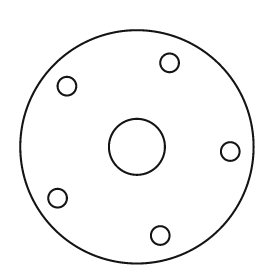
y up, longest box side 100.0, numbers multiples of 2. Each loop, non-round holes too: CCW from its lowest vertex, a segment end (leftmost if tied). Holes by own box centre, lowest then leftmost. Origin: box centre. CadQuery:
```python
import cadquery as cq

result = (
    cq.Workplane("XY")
    .moveTo(0.0, 0.0)
    .circle(50.0)
    .moveTo(10.0, -38.0)
    .circle(4.0)
    .moveTo(-34.0, -22.0)
    .circle(4.0)
    .moveTo(40.0, -2.0)
    .circle(4.0)
    .moveTo(0.0, 0.0)
    .circle(12.0)
    .moveTo(-30.0, 26.0)
    .circle(4.0)
    .moveTo(14.0, 36.0)
    .circle(4.0)
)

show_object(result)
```